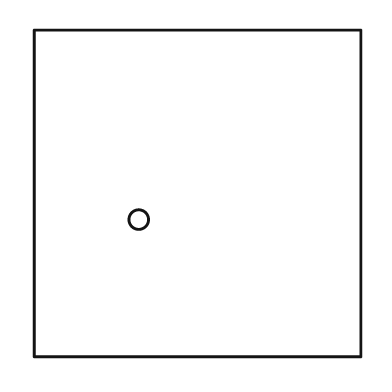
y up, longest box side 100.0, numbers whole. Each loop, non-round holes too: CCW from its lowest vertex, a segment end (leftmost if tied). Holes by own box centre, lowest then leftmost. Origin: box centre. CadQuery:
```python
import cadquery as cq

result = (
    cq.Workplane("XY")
    .moveTo(-50.0, -50.0)
    .lineTo(50.0, -50.0)
    .lineTo(50.0, 50.0)
    .lineTo(-50.0, 50.0)
    .close()
    .moveTo(-18.0, -8.0)
    .circle(3.0)
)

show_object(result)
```